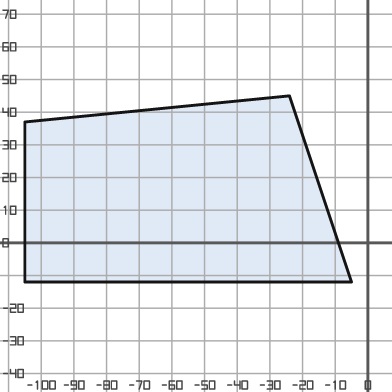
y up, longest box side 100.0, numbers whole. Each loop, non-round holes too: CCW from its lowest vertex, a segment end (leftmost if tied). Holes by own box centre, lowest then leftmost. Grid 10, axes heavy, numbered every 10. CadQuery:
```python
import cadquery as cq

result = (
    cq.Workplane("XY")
    .moveTo(-105.0, -12.0)
    .lineTo(-5.0, -12.0)
    .lineTo(-24.0, 45.0)
    .lineTo(-105.0, 37.0)
    .close()
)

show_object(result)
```